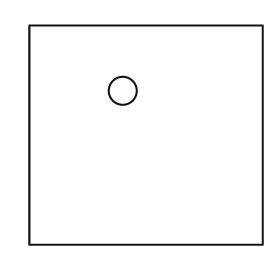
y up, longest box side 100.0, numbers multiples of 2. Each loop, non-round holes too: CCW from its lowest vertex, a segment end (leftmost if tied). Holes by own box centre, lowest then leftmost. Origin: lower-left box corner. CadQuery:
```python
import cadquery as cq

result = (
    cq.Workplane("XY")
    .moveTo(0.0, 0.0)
    .lineTo(100.0, 0.0)
    .lineTo(100.0, 94.0)
    .lineTo(0.0, 94.0)
    .close()
    .moveTo(40.0, 66.0)
    .circle(6.0)
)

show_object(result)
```